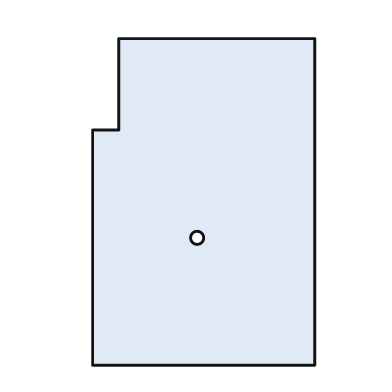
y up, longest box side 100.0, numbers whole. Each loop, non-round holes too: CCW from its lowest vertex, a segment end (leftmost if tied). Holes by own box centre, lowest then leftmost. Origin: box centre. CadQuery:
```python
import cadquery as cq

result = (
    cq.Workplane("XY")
    .moveTo(-34.0, -50.0)
    .lineTo(34.0, -50.0)
    .lineTo(34.0, 50.0)
    .lineTo(-26.0, 50.0)
    .lineTo(-26.0, 22.0)
    .lineTo(-34.0, 22.0)
    .close()
    .moveTo(-2.0, -11.0)
    .circle(2.0)
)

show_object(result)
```